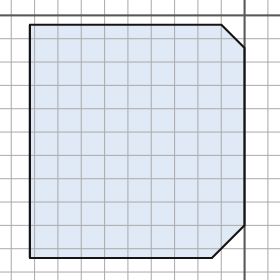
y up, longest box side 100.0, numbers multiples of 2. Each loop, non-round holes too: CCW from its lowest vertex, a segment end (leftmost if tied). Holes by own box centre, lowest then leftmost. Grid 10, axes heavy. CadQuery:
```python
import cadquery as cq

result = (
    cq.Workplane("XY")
    .moveTo(-92.0, -104.0)
    .lineTo(-14.0, -104.0)
    .lineTo(0.0, -90.0)
    .lineTo(0.0, -14.0)
    .lineTo(-10.0, -4.0)
    .lineTo(-92.0, -4.0)
    .close()
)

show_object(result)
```